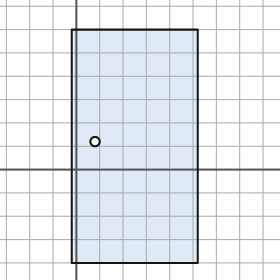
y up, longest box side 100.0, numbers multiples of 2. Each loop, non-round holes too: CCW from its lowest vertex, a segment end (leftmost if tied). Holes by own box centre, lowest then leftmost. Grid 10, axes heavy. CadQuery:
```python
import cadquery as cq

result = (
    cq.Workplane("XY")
    .moveTo(-2.0, -40.0)
    .lineTo(52.0, -40.0)
    .lineTo(52.0, 60.0)
    .lineTo(-2.0, 60.0)
    .close()
    .moveTo(8.0, 12.0)
    .circle(2.0)
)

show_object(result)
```